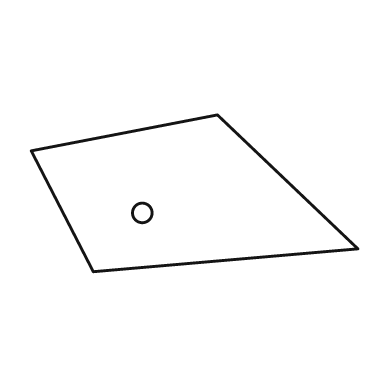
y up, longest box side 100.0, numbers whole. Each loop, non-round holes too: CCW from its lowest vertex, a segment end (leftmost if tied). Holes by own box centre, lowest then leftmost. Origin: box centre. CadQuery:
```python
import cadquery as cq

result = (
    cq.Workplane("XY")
    .moveTo(-31.0, -24.0)
    .lineTo(50.0, -17.0)
    .lineTo(7.0, 24.0)
    .lineTo(-50.0, 13.0)
    .close()
    .moveTo(-16.0, -6.0)
    .circle(3.0)
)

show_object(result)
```